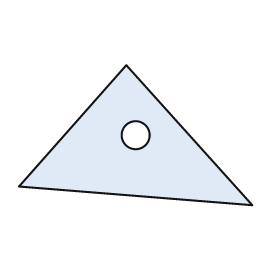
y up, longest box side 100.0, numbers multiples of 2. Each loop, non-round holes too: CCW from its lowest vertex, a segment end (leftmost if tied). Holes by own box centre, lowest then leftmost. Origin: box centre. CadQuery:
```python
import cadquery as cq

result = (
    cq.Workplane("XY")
    .moveTo(50.0, -30.0)
    .lineTo(-4.0, 30.0)
    .lineTo(-50.0, -22.0)
    .close()
    .moveTo(0.0, 0.0)
    .circle(6.0)
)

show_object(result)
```